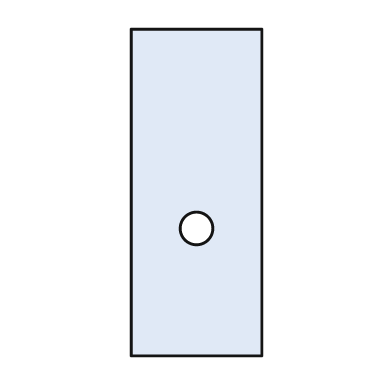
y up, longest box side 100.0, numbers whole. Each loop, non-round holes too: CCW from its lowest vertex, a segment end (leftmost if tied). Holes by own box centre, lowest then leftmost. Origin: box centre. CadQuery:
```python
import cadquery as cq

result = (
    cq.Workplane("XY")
    .moveTo(-20.0, -50.0)
    .lineTo(20.0, -50.0)
    .lineTo(20.0, 50.0)
    .lineTo(-20.0, 50.0)
    .close()
    .moveTo(0.0, -11.0)
    .circle(5.0)
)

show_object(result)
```